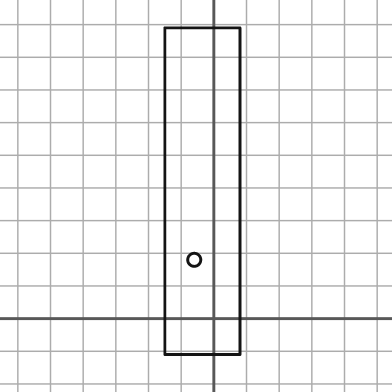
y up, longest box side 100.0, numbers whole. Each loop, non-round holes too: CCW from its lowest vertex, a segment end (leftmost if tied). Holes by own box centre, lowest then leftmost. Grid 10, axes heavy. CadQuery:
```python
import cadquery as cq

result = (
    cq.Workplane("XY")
    .moveTo(-15.0, -11.0)
    .lineTo(8.0, -11.0)
    .lineTo(8.0, 89.0)
    .lineTo(-15.0, 89.0)
    .close()
    .moveTo(-6.0, 18.0)
    .circle(2.0)
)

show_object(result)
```